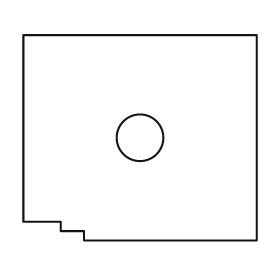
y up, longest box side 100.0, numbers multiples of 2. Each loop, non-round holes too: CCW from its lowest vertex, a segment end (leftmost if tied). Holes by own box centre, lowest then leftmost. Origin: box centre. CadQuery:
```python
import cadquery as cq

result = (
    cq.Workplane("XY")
    .moveTo(-24.0, -44.0)
    .lineTo(50.0, -44.0)
    .lineTo(50.0, 44.0)
    .lineTo(-50.0, 44.0)
    .lineTo(-50.0, -36.0)
    .lineTo(-34.0, -36.0)
    .lineTo(-34.0, -40.0)
    .lineTo(-24.0, -40.0)
    .close()
    .moveTo(0.0, 0.0)
    .circle(10.0)
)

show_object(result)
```